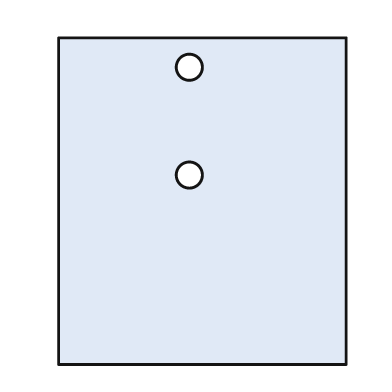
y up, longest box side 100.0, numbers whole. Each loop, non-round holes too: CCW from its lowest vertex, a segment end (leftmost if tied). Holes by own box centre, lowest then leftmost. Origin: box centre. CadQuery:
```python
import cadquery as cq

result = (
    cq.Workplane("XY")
    .moveTo(-44.0, -50.0)
    .lineTo(44.0, -50.0)
    .lineTo(44.0, 50.0)
    .lineTo(-44.0, 50.0)
    .close()
    .moveTo(-4.0, 8.0)
    .circle(4.0)
    .moveTo(-4.0, 41.0)
    .circle(4.0)
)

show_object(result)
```